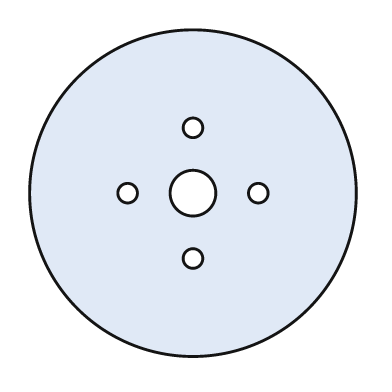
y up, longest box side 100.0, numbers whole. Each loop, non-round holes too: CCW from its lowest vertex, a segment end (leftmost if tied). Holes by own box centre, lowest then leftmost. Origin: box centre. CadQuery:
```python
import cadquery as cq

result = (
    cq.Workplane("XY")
    .moveTo(0.0, 0.0)
    .circle(50.0)
    .moveTo(0.0, -20.0)
    .circle(3.0)
    .moveTo(-20.0, 0.0)
    .circle(3.0)
    .moveTo(0.0, 0.0)
    .circle(7.0)
    .moveTo(20.0, 0.0)
    .circle(3.0)
    .moveTo(0.0, 20.0)
    .circle(3.0)
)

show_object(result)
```